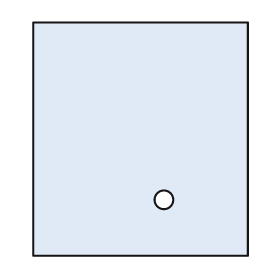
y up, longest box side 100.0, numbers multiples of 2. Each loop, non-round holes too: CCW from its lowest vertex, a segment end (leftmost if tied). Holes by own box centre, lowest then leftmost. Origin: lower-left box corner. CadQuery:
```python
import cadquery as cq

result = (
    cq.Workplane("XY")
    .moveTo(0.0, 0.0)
    .lineTo(92.0, 0.0)
    .lineTo(92.0, 100.0)
    .lineTo(0.0, 100.0)
    .close()
    .moveTo(56.0, 24.0)
    .circle(4.0)
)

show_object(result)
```